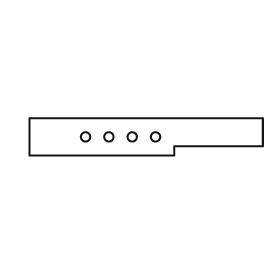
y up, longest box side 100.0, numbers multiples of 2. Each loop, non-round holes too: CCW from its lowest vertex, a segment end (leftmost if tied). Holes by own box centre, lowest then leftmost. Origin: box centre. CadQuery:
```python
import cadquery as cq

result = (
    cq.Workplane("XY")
    .moveTo(-50.0, -8.0)
    .lineTo(12.0, -8.0)
    .lineTo(12.0, -4.0)
    .lineTo(50.0, -4.0)
    .lineTo(50.0, 8.0)
    .lineTo(-50.0, 8.0)
    .close()
    .moveTo(-26.0, 0.0)
    .circle(2.0)
    .moveTo(-16.0, 0.0)
    .circle(2.0)
    .moveTo(-6.0, 0.0)
    .circle(2.0)
    .moveTo(4.0, 0.0)
    .circle(2.0)
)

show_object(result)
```